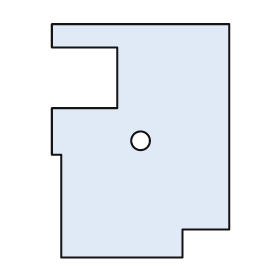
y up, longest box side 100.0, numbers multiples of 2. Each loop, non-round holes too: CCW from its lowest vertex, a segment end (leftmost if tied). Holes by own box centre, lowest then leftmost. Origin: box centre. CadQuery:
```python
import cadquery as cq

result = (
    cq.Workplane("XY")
    .moveTo(-34.0, -50.0)
    .lineTo(18.0, -50.0)
    .lineTo(18.0, -38.0)
    .lineTo(38.0, -38.0)
    .lineTo(38.0, 50.0)
    .lineTo(-38.0, 50.0)
    .lineTo(-38.0, 40.0)
    .lineTo(-10.0, 40.0)
    .lineTo(-10.0, 14.0)
    .lineTo(-38.0, 14.0)
    .lineTo(-38.0, -6.0)
    .lineTo(-34.0, -6.0)
    .close()
    .moveTo(0.0, 0.0)
    .circle(4.0)
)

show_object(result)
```